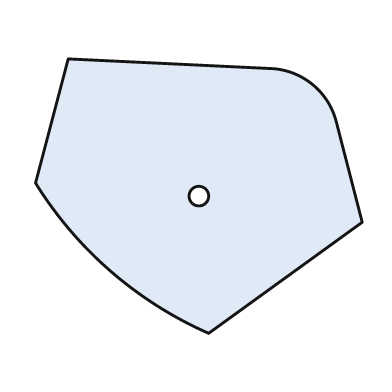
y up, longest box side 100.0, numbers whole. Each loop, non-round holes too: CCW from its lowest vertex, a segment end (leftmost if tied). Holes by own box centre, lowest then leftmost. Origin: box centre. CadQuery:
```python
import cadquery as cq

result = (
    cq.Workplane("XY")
    .moveTo(3.0, -42.0)
    .lineTo(50.0, -8.0)
    .lineTo(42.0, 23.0)
    .threePointArc((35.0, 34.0), (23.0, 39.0))
    .lineTo(-40.0, 42.0)
    .lineTo(-50.0, 4.0)
    .threePointArc((-27.0, -23.0), (3.0, -42.0))
    .close()
    .moveTo(0.0, 0.0)
    .circle(3.0)
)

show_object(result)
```